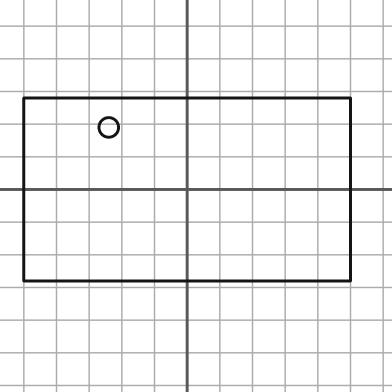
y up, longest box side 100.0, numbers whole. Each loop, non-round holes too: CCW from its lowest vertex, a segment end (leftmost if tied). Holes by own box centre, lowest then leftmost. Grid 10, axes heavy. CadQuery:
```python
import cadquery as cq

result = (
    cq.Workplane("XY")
    .moveTo(-50.0, -28.0)
    .lineTo(50.0, -28.0)
    .lineTo(50.0, 28.0)
    .lineTo(-50.0, 28.0)
    .close()
    .moveTo(-24.0, 19.0)
    .circle(3.0)
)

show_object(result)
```